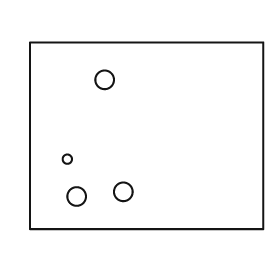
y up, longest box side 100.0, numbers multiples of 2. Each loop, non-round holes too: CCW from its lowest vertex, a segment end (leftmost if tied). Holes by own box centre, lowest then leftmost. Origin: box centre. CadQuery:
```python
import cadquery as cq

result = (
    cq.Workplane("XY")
    .moveTo(-50.0, -40.0)
    .lineTo(50.0, -40.0)
    .lineTo(50.0, 40.0)
    .lineTo(-50.0, 40.0)
    .close()
    .moveTo(-30.0, -26.0)
    .circle(4.0)
    .moveTo(-10.0, -24.0)
    .circle(4.0)
    .moveTo(-34.0, -10.0)
    .circle(2.0)
    .moveTo(-18.0, 24.0)
    .circle(4.0)
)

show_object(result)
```